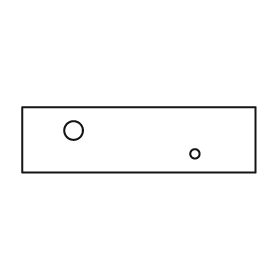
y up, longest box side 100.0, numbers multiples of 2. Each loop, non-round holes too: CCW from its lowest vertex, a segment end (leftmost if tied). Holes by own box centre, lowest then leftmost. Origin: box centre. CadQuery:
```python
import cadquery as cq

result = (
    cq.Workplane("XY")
    .moveTo(-50.0, -14.0)
    .lineTo(50.0, -14.0)
    .lineTo(50.0, 14.0)
    .lineTo(-50.0, 14.0)
    .close()
    .moveTo(24.0, -6.0)
    .circle(2.0)
    .moveTo(-28.0, 4.0)
    .circle(4.0)
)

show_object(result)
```